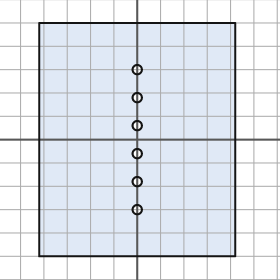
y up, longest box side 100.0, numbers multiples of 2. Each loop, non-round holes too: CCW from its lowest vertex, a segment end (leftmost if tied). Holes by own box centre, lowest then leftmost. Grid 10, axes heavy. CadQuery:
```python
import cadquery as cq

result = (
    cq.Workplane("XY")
    .moveTo(-42.0, -50.0)
    .lineTo(42.0, -50.0)
    .lineTo(42.0, 50.0)
    .lineTo(-42.0, 50.0)
    .close()
    .moveTo(0.0, -30.0)
    .circle(2.0)
    .moveTo(0.0, -18.0)
    .circle(2.0)
    .moveTo(0.0, -6.0)
    .circle(2.0)
    .moveTo(0.0, 6.0)
    .circle(2.0)
    .moveTo(0.0, 18.0)
    .circle(2.0)
    .moveTo(0.0, 30.0)
    .circle(2.0)
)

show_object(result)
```